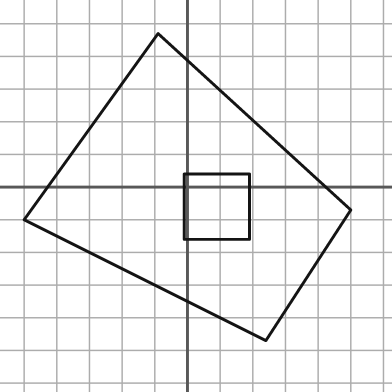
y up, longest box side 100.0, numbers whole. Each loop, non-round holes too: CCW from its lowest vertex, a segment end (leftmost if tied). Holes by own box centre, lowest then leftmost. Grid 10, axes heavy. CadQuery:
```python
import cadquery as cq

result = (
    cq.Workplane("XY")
    .moveTo(24.0, -47.0)
    .lineTo(50.0, -7.0)
    .lineTo(-9.0, 47.0)
    .lineTo(-50.0, -10.0)
    .close()
    .moveTo(-1.0, -16.0)
    .lineTo(19.0, -16.0)
    .lineTo(19.0, 4.0)
    .lineTo(-1.0, 4.0)
    .close()
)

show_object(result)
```